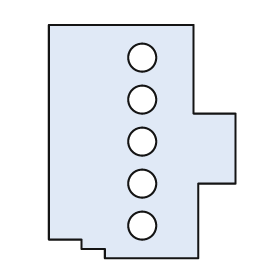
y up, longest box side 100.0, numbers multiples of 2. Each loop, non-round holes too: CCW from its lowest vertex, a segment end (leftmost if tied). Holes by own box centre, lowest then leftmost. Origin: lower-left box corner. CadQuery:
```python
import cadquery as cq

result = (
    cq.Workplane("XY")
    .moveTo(24.0, 0.0)
    .lineTo(64.0, 0.0)
    .lineTo(64.0, 32.0)
    .lineTo(80.0, 32.0)
    .lineTo(80.0, 62.0)
    .lineTo(62.0, 62.0)
    .lineTo(62.0, 100.0)
    .lineTo(0.0, 100.0)
    .lineTo(0.0, 8.0)
    .lineTo(14.0, 8.0)
    .lineTo(14.0, 4.0)
    .lineTo(24.0, 4.0)
    .close()
    .moveTo(40.0, 14.0)
    .circle(6.0)
    .moveTo(40.0, 32.0)
    .circle(6.0)
    .moveTo(40.0, 50.0)
    .circle(6.0)
    .moveTo(40.0, 68.0)
    .circle(6.0)
    .moveTo(40.0, 86.0)
    .circle(6.0)
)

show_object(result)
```